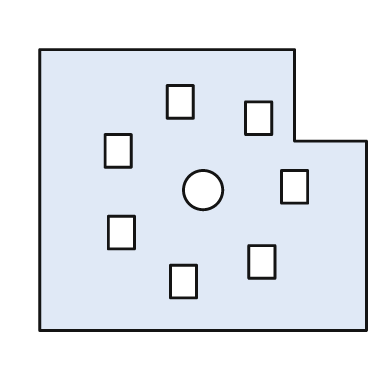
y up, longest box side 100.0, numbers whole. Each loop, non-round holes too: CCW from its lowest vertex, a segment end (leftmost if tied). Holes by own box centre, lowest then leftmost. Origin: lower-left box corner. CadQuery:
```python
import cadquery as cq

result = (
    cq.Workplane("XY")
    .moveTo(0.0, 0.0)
    .lineTo(100.0, 0.0)
    .lineTo(100.0, 58.0)
    .lineTo(78.0, 58.0)
    .lineTo(78.0, 86.0)
    .lineTo(0.0, 86.0)
    .close()
    .moveTo(40.0, 10.0)
    .lineTo(48.0, 10.0)
    .lineTo(48.0, 20.0)
    .lineTo(40.0, 20.0)
    .close()
    .moveTo(64.0, 16.0)
    .lineTo(72.0, 16.0)
    .lineTo(72.0, 26.0)
    .lineTo(64.0, 26.0)
    .close()
    .moveTo(21.0, 25.0)
    .lineTo(29.0, 25.0)
    .lineTo(29.0, 35.0)
    .lineTo(21.0, 35.0)
    .close()
    .moveTo(50.0, 43.0)
    .circle(6.0)
    .moveTo(74.0, 39.0)
    .lineTo(82.0, 39.0)
    .lineTo(82.0, 49.0)
    .lineTo(74.0, 49.0)
    .close()
    .moveTo(20.0, 50.0)
    .lineTo(28.0, 50.0)
    .lineTo(28.0, 60.0)
    .lineTo(20.0, 60.0)
    .close()
    .moveTo(63.0, 60.0)
    .lineTo(71.0, 60.0)
    .lineTo(71.0, 70.0)
    .lineTo(63.0, 70.0)
    .close()
    .moveTo(39.0, 65.0)
    .lineTo(47.0, 65.0)
    .lineTo(47.0, 75.0)
    .lineTo(39.0, 75.0)
    .close()
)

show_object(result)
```